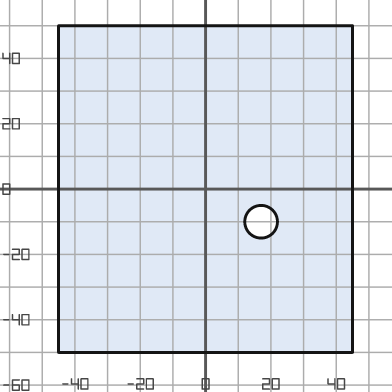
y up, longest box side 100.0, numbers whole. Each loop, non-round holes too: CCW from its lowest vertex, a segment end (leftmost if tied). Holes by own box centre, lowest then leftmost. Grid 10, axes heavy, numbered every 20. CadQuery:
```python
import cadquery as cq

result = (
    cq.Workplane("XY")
    .moveTo(-45.0, -50.0)
    .lineTo(45.0, -50.0)
    .lineTo(45.0, 50.0)
    .lineTo(-45.0, 50.0)
    .close()
    .moveTo(17.0, -10.0)
    .circle(5.0)
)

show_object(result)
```